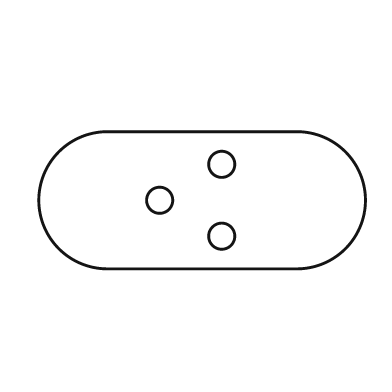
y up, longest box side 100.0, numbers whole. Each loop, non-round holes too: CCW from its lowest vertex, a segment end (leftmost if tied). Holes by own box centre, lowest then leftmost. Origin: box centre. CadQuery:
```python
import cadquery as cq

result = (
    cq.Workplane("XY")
    .moveTo(-29.0, -21.0)
    .lineTo(29.0, -21.0)
    .threePointArc((50.0, 0.0), (29.0, 21.0))
    .lineTo(-29.0, 21.0)
    .threePointArc((-50.0, 0.0), (-29.0, -21.0))
    .close()
    .moveTo(6.0, -11.0)
    .circle(4.0)
    .moveTo(-13.0, 0.0)
    .circle(4.0)
    .moveTo(6.0, 11.0)
    .circle(4.0)
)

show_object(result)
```